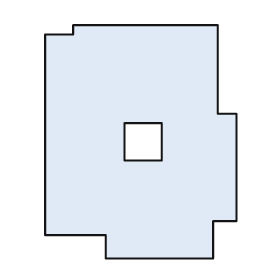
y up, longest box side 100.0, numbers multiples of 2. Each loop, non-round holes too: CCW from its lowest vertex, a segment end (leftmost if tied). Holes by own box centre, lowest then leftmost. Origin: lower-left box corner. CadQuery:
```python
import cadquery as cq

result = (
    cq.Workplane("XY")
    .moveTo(26.0, 0.0)
    .lineTo(72.0, 0.0)
    .lineTo(72.0, 16.0)
    .lineTo(82.0, 16.0)
    .lineTo(82.0, 62.0)
    .lineTo(74.0, 62.0)
    .lineTo(74.0, 100.0)
    .lineTo(12.0, 100.0)
    .lineTo(12.0, 96.0)
    .lineTo(0.0, 96.0)
    .lineTo(0.0, 10.0)
    .lineTo(26.0, 10.0)
    .close()
    .moveTo(34.0, 42.0)
    .lineTo(50.0, 42.0)
    .lineTo(50.0, 58.0)
    .lineTo(34.0, 58.0)
    .close()
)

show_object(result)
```